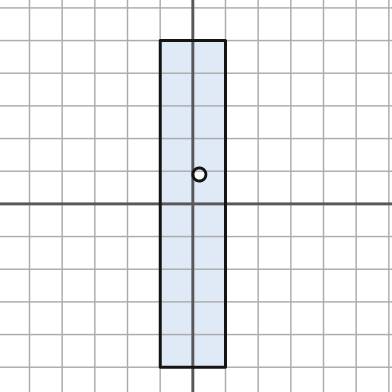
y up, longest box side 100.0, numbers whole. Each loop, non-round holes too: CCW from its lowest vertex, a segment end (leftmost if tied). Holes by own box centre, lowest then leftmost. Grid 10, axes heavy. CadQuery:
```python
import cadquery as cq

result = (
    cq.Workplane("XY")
    .moveTo(-10.0, -50.0)
    .lineTo(10.0, -50.0)
    .lineTo(10.0, 50.0)
    .lineTo(-10.0, 50.0)
    .close()
    .moveTo(2.0, 9.0)
    .circle(2.0)
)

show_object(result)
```